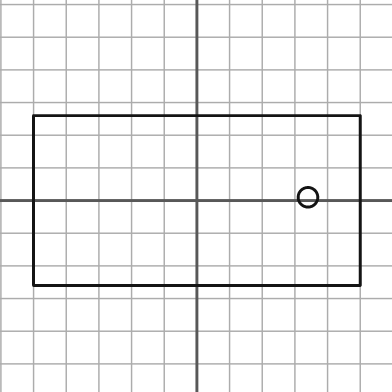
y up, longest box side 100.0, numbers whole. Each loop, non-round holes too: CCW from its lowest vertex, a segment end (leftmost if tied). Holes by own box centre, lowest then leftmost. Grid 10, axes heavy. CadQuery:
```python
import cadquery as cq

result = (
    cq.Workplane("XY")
    .moveTo(-50.0, -26.0)
    .lineTo(50.0, -26.0)
    .lineTo(50.0, 26.0)
    .lineTo(-50.0, 26.0)
    .close()
    .moveTo(34.0, 1.0)
    .circle(3.0)
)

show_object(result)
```